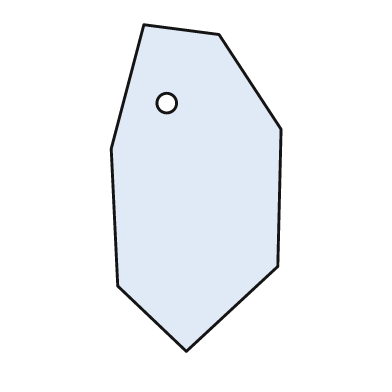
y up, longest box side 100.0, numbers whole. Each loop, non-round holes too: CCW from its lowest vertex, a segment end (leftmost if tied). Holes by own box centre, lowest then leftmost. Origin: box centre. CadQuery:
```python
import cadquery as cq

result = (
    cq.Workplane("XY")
    .moveTo(-3.0, -50.0)
    .lineTo(25.0, -24.0)
    .lineTo(26.0, 18.0)
    .lineTo(7.0, 47.0)
    .lineTo(-16.0, 50.0)
    .lineTo(-26.0, 12.0)
    .lineTo(-24.0, -30.0)
    .close()
    .moveTo(-9.0, 26.0)
    .circle(3.0)
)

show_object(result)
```